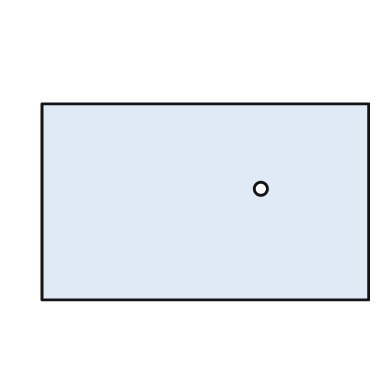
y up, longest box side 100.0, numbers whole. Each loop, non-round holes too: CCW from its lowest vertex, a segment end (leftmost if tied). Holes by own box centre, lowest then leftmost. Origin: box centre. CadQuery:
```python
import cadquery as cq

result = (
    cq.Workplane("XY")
    .moveTo(-50.0, -30.0)
    .lineTo(50.0, -30.0)
    .lineTo(50.0, 30.0)
    .lineTo(-50.0, 30.0)
    .close()
    .moveTo(17.0, 4.0)
    .circle(2.0)
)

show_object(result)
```